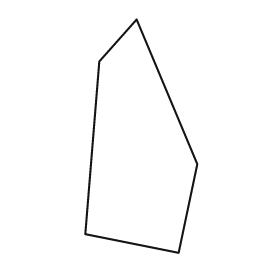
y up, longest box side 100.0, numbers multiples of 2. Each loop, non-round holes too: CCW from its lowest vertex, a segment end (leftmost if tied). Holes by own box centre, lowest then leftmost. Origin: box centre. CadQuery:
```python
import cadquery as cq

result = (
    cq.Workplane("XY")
    .moveTo(16.0, -50.0)
    .lineTo(24.0, -12.0)
    .lineTo(-2.0, 50.0)
    .lineTo(-18.0, 32.0)
    .lineTo(-24.0, -42.0)
    .close()
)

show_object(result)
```